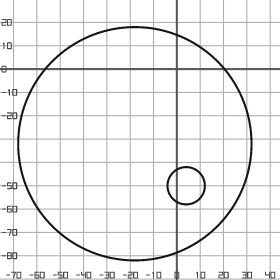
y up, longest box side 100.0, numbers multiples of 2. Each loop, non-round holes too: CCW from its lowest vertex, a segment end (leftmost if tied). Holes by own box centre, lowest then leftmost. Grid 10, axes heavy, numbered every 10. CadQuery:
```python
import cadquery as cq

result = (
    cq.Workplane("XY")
    .moveTo(-18.0, -32.0)
    .circle(50.0)
    .moveTo(4.0, -50.0)
    .circle(8.0)
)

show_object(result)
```